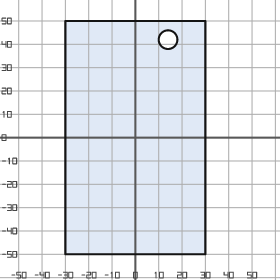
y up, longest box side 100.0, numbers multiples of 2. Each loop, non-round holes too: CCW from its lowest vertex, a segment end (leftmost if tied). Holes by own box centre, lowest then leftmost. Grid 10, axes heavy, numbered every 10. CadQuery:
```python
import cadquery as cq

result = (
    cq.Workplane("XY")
    .moveTo(-30.0, -50.0)
    .lineTo(30.0, -50.0)
    .lineTo(30.0, 50.0)
    .lineTo(-30.0, 50.0)
    .close()
    .moveTo(14.0, 42.0)
    .circle(4.0)
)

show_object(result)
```